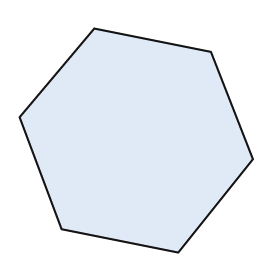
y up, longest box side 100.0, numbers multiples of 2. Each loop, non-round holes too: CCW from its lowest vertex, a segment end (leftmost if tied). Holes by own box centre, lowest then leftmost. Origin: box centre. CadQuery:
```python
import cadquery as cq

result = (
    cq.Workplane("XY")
    .moveTo(18.0, -48.0)
    .lineTo(50.0, -8.0)
    .lineTo(32.0, 38.0)
    .lineTo(-18.0, 48.0)
    .lineTo(-50.0, 10.0)
    .lineTo(-32.0, -38.0)
    .close()
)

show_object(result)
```